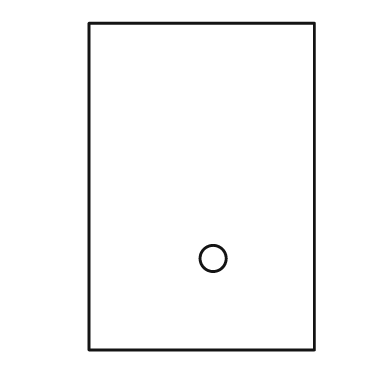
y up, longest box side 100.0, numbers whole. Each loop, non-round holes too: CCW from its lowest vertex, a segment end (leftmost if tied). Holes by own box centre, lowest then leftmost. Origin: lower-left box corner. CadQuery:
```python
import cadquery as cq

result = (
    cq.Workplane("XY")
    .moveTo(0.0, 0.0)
    .lineTo(69.0, 0.0)
    .lineTo(69.0, 100.0)
    .lineTo(0.0, 100.0)
    .close()
    .moveTo(38.0, 28.0)
    .circle(4.0)
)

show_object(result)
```